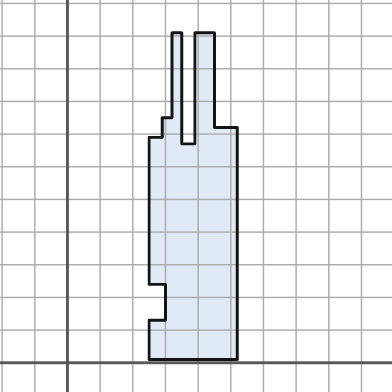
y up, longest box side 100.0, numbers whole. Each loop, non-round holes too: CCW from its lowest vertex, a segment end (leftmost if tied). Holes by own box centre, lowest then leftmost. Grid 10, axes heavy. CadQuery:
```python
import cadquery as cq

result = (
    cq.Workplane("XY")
    .moveTo(25.0, 1.0)
    .lineTo(52.0, 1.0)
    .lineTo(52.0, 72.0)
    .lineTo(45.0, 72.0)
    .lineTo(45.0, 101.0)
    .lineTo(39.0, 101.0)
    .lineTo(39.0, 67.0)
    .lineTo(35.0, 67.0)
    .lineTo(35.0, 101.0)
    .lineTo(32.0, 101.0)
    .lineTo(32.0, 75.0)
    .lineTo(29.0, 75.0)
    .lineTo(29.0, 69.0)
    .lineTo(25.0, 69.0)
    .lineTo(25.0, 24.0)
    .lineTo(30.0, 24.0)
    .lineTo(30.0, 13.0)
    .lineTo(25.0, 13.0)
    .close()
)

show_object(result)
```